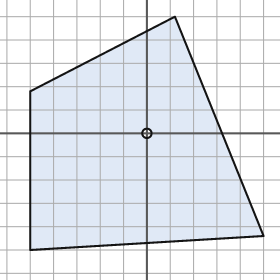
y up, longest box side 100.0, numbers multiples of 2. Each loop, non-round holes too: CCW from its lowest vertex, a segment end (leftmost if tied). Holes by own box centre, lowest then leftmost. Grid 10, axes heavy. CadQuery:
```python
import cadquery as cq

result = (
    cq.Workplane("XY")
    .moveTo(-50.0, -50.0)
    .lineTo(50.0, -44.0)
    .lineTo(12.0, 50.0)
    .lineTo(-50.0, 18.0)
    .close()
    .moveTo(0.0, 0.0)
    .circle(2.0)
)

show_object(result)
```